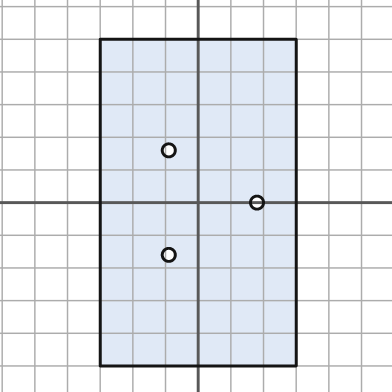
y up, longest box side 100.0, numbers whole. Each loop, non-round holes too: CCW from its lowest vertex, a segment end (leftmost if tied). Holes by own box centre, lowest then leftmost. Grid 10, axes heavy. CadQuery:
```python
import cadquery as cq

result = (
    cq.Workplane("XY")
    .moveTo(-30.0, -50.0)
    .lineTo(30.0, -50.0)
    .lineTo(30.0, 50.0)
    .lineTo(-30.0, 50.0)
    .close()
    .moveTo(-9.0, -16.0)
    .circle(2.0)
    .moveTo(18.0, 0.0)
    .circle(2.0)
    .moveTo(-9.0, 16.0)
    .circle(2.0)
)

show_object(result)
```